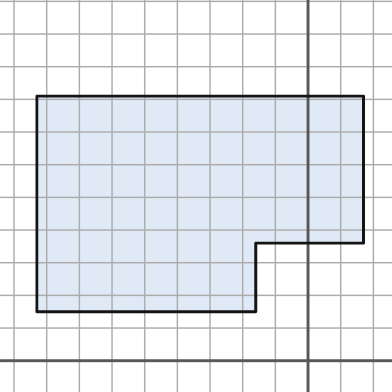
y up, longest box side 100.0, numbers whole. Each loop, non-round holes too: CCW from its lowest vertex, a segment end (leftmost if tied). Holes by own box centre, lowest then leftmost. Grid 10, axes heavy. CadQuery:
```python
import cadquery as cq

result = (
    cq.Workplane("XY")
    .moveTo(-83.0, 15.0)
    .lineTo(-16.0, 15.0)
    .lineTo(-16.0, 36.0)
    .lineTo(17.0, 36.0)
    .lineTo(17.0, 81.0)
    .lineTo(-83.0, 81.0)
    .close()
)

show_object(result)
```